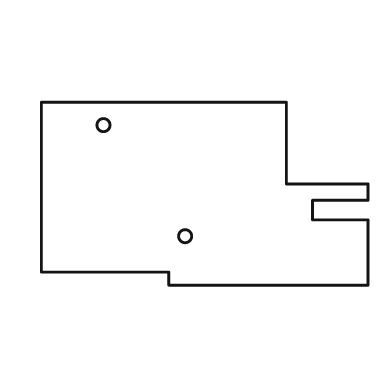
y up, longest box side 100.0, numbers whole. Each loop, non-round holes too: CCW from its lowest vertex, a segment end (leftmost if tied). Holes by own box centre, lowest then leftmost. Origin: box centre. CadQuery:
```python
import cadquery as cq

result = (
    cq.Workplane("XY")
    .moveTo(-11.0, -28.0)
    .lineTo(50.0, -28.0)
    .lineTo(50.0, -8.0)
    .lineTo(33.0, -8.0)
    .lineTo(33.0, -2.0)
    .lineTo(50.0, -2.0)
    .lineTo(50.0, 3.0)
    .lineTo(25.0, 3.0)
    .lineTo(25.0, 28.0)
    .lineTo(-50.0, 28.0)
    .lineTo(-50.0, -24.0)
    .lineTo(-11.0, -24.0)
    .close()
    .moveTo(-6.0, -13.0)
    .circle(2.0)
    .moveTo(-31.0, 21.0)
    .circle(2.0)
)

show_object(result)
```